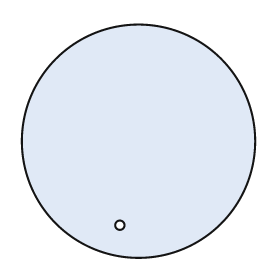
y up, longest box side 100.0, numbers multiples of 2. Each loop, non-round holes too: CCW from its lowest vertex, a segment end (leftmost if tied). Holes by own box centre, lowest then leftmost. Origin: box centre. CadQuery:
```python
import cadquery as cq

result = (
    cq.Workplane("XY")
    .moveTo(0.0, 0.0)
    .circle(50.0)
    .moveTo(-8.0, -36.0)
    .circle(2.0)
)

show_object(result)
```